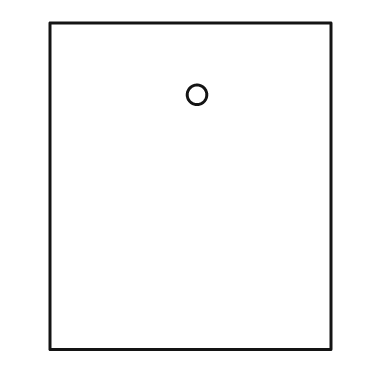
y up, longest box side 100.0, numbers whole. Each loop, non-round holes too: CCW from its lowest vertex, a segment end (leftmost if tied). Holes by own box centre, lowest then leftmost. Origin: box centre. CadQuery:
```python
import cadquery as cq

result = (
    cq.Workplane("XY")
    .moveTo(-43.0, -50.0)
    .lineTo(43.0, -50.0)
    .lineTo(43.0, 50.0)
    .lineTo(-43.0, 50.0)
    .close()
    .moveTo(2.0, 28.0)
    .circle(3.0)
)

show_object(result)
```